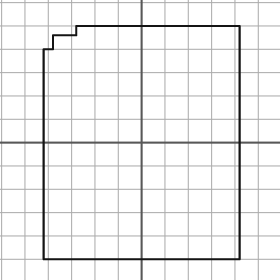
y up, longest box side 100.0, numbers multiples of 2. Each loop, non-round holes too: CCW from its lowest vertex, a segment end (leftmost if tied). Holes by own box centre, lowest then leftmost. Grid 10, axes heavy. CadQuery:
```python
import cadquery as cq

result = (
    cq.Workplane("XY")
    .moveTo(-42.0, -50.0)
    .lineTo(42.0, -50.0)
    .lineTo(42.0, 50.0)
    .lineTo(-28.0, 50.0)
    .lineTo(-28.0, 46.0)
    .lineTo(-38.0, 46.0)
    .lineTo(-38.0, 40.0)
    .lineTo(-42.0, 40.0)
    .close()
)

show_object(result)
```